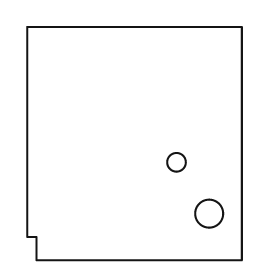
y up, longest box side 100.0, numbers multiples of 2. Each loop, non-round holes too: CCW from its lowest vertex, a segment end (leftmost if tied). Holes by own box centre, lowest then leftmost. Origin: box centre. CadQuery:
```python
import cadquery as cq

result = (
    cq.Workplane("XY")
    .moveTo(-42.0, -50.0)
    .lineTo(46.0, -50.0)
    .lineTo(46.0, 50.0)
    .lineTo(-46.0, 50.0)
    .lineTo(-46.0, -40.0)
    .lineTo(-42.0, -40.0)
    .close()
    .moveTo(32.0, -30.0)
    .circle(6.0)
    .moveTo(18.0, -8.0)
    .circle(4.0)
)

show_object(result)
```